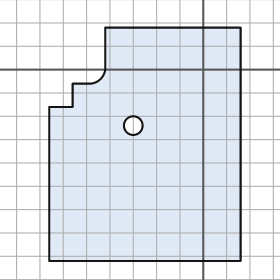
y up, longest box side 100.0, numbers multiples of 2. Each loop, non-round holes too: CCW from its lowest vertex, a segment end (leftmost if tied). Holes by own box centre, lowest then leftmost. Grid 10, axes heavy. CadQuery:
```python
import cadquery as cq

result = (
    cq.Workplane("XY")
    .moveTo(-66.0, -82.0)
    .lineTo(16.0, -82.0)
    .lineTo(16.0, 18.0)
    .lineTo(-42.0, 18.0)
    .lineTo(-42.0, 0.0)
    .threePointArc((-44.0, -4.0), (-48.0, -6.0))
    .lineTo(-56.0, -6.0)
    .lineTo(-56.0, -16.0)
    .lineTo(-66.0, -16.0)
    .close()
    .moveTo(-30.0, -24.0)
    .circle(4.0)
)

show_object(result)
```